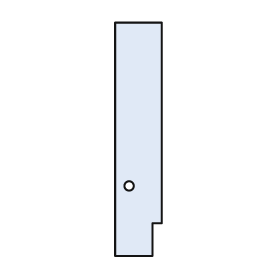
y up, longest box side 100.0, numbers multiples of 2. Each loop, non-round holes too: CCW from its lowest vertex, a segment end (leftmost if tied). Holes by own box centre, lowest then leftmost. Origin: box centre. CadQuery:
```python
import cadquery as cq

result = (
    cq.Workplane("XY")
    .moveTo(-10.0, -50.0)
    .lineTo(6.0, -50.0)
    .lineTo(6.0, -36.0)
    .lineTo(10.0, -36.0)
    .lineTo(10.0, 50.0)
    .lineTo(-10.0, 50.0)
    .close()
    .moveTo(-4.0, -20.0)
    .circle(2.0)
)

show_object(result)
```